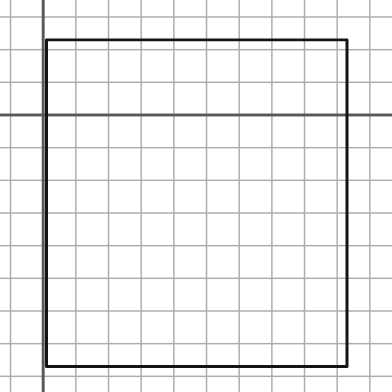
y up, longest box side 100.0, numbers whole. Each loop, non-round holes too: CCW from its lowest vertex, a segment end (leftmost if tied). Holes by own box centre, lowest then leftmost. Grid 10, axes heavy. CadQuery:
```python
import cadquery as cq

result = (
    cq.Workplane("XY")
    .moveTo(1.0, -77.0)
    .lineTo(93.0, -77.0)
    .lineTo(93.0, 23.0)
    .lineTo(1.0, 23.0)
    .close()
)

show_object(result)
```